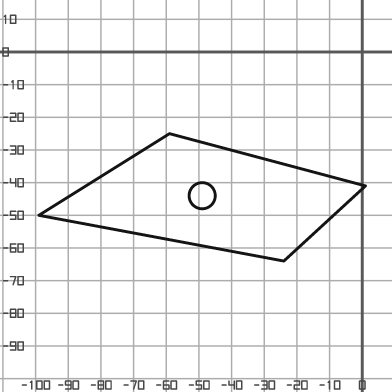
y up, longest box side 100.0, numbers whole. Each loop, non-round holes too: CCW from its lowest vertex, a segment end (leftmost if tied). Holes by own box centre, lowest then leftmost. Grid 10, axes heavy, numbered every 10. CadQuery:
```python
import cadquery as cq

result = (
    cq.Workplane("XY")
    .moveTo(-24.0, -64.0)
    .lineTo(1.0, -41.0)
    .lineTo(-59.0, -25.0)
    .lineTo(-99.0, -50.0)
    .close()
    .moveTo(-49.0, -44.0)
    .circle(4.0)
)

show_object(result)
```